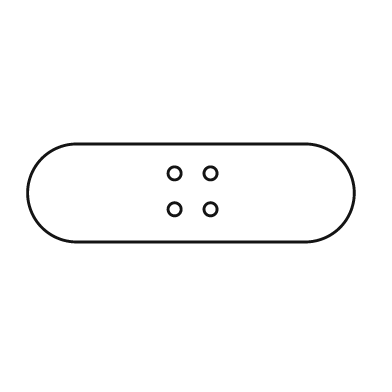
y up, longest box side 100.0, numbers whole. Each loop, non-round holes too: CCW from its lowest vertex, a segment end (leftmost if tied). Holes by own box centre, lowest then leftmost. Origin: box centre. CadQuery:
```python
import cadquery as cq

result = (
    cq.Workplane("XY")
    .moveTo(-35.0, -15.0)
    .lineTo(35.0, -15.0)
    .threePointArc((50.0, 0.0), (35.0, 15.0))
    .lineTo(-35.0, 15.0)
    .threePointArc((-50.0, 0.0), (-35.0, -15.0))
    .close()
    .moveTo(-5.0, -5.0)
    .circle(2.0)
    .moveTo(6.0, -5.0)
    .circle(2.0)
    .moveTo(-5.0, 6.0)
    .circle(2.0)
    .moveTo(6.0, 6.0)
    .circle(2.0)
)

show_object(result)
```